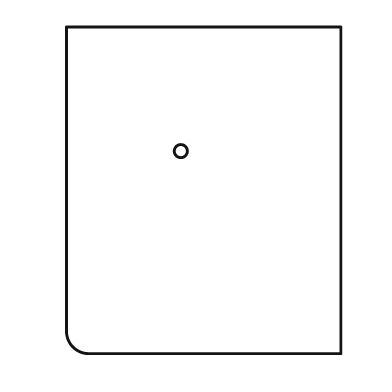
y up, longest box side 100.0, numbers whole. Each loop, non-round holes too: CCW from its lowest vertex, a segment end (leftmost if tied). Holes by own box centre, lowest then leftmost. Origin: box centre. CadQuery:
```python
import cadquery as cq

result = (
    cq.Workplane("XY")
    .moveTo(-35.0, -50.0)
    .lineTo(42.0, -50.0)
    .lineTo(42.0, 50.0)
    .lineTo(-42.0, 50.0)
    .lineTo(-42.0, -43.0)
    .threePointArc((-40.0, -48.0), (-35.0, -50.0))
    .close()
    .moveTo(-7.0, 12.0)
    .circle(2.0)
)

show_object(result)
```